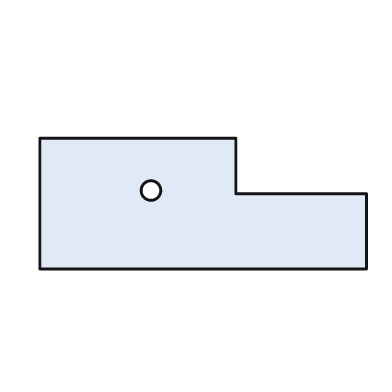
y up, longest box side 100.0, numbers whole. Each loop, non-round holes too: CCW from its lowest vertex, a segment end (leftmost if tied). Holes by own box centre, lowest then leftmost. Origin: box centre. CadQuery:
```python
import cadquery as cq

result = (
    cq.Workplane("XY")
    .moveTo(-50.0, -20.0)
    .lineTo(50.0, -20.0)
    .lineTo(50.0, 3.0)
    .lineTo(10.0, 3.0)
    .lineTo(10.0, 20.0)
    .lineTo(-50.0, 20.0)
    .close()
    .moveTo(-16.0, 4.0)
    .circle(3.0)
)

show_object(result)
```